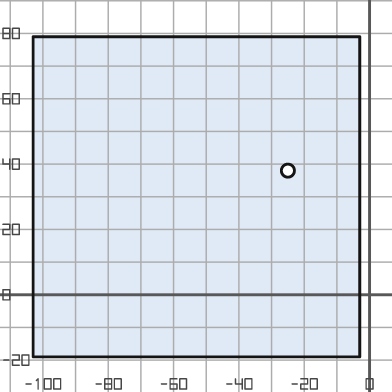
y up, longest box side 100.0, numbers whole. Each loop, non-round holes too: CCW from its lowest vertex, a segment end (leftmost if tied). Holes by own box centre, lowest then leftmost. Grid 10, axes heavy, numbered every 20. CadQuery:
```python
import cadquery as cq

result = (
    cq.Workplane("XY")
    .moveTo(-103.0, -19.0)
    .lineTo(-3.0, -19.0)
    .lineTo(-3.0, 79.0)
    .lineTo(-103.0, 79.0)
    .close()
    .moveTo(-25.0, 38.0)
    .circle(2.0)
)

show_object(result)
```